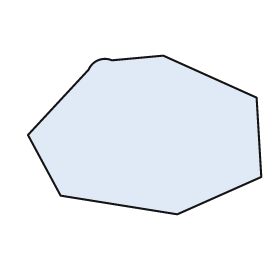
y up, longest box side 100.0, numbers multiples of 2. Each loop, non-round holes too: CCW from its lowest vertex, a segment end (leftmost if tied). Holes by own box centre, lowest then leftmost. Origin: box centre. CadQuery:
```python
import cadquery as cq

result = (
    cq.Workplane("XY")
    .moveTo(14.0, -34.0)
    .lineTo(50.0, -18.0)
    .lineTo(48.0, 16.0)
    .lineTo(8.0, 34.0)
    .lineTo(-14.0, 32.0)
    .threePointArc((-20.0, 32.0), (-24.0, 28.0))
    .lineTo(-50.0, 0.0)
    .lineTo(-36.0, -26.0)
    .close()
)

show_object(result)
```